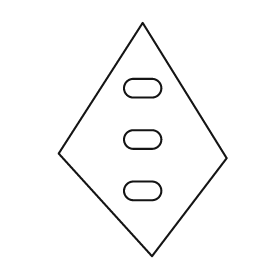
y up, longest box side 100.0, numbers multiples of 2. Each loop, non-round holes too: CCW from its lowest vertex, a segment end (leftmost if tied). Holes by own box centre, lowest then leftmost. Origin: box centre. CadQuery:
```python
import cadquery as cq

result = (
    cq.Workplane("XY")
    .moveTo(4.0, -50.0)
    .lineTo(36.0, -8.0)
    .lineTo(0.0, 50.0)
    .lineTo(-36.0, -6.0)
    .close()
    .moveTo(-4.0, -26.0)
    .lineTo(4.0, -26.0)
    .threePointArc((8.0, -22.0), (4.0, -18.0))
    .lineTo(-4.0, -18.0)
    .threePointArc((-8.0, -22.0), (-4.0, -26.0))
    .close()
    .moveTo(-4.0, -4.0)
    .lineTo(4.0, -4.0)
    .threePointArc((8.0, 0.0), (4.0, 4.0))
    .lineTo(-4.0, 4.0)
    .threePointArc((-8.0, 0.0), (-4.0, -4.0))
    .close()
    .moveTo(-4.0, 18.0)
    .lineTo(4.0, 18.0)
    .threePointArc((8.0, 22.0), (4.0, 26.0))
    .lineTo(-4.0, 26.0)
    .threePointArc((-8.0, 22.0), (-4.0, 18.0))
    .close()
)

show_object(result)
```